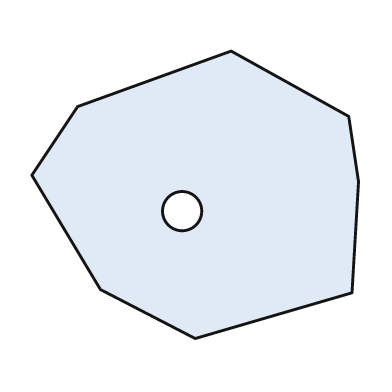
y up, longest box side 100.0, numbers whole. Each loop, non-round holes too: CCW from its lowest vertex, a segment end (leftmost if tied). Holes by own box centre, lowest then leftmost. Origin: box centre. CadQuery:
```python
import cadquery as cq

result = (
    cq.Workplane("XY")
    .moveTo(0.0, -44.0)
    .lineTo(48.0, -30.0)
    .lineTo(50.0, 4.0)
    .lineTo(47.0, 24.0)
    .lineTo(11.0, 44.0)
    .lineTo(-36.0, 27.0)
    .lineTo(-50.0, 6.0)
    .lineTo(-29.0, -29.0)
    .close()
    .moveTo(-4.0, -5.0)
    .circle(6.0)
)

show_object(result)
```